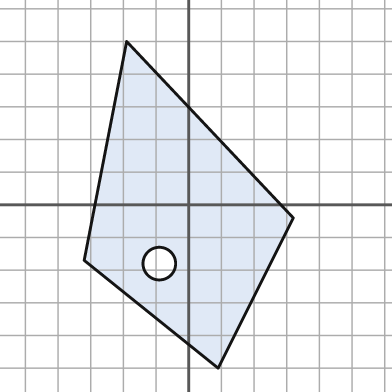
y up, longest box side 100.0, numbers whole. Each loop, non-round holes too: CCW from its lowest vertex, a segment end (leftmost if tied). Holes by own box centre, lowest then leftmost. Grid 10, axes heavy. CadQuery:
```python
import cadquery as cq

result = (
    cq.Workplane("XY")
    .moveTo(9.0, -50.0)
    .lineTo(32.0, -4.0)
    .lineTo(-19.0, 50.0)
    .lineTo(-32.0, -17.0)
    .close()
    .moveTo(-9.0, -18.0)
    .circle(5.0)
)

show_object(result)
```